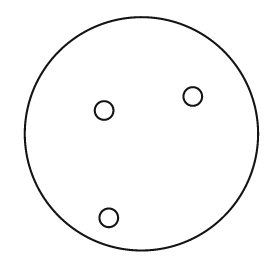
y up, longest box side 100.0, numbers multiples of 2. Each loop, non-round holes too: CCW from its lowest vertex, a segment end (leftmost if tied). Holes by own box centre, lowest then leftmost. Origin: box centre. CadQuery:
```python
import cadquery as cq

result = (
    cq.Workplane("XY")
    .moveTo(0.0, 0.0)
    .circle(50.0)
    .moveTo(-14.0, -36.0)
    .circle(4.0)
    .moveTo(-16.0, 10.0)
    .circle(4.0)
    .moveTo(22.0, 16.0)
    .circle(4.0)
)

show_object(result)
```